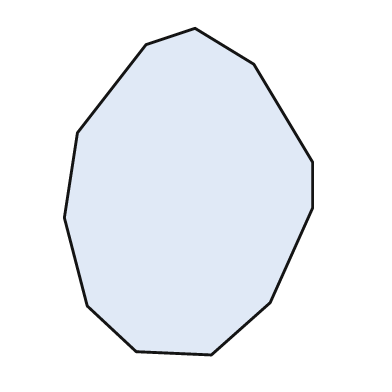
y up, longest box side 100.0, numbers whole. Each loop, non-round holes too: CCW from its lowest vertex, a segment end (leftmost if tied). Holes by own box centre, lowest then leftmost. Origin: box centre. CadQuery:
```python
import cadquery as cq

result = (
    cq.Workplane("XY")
    .moveTo(7.0, -50.0)
    .lineTo(25.0, -34.0)
    .lineTo(38.0, -5.0)
    .lineTo(38.0, 9.0)
    .lineTo(20.0, 39.0)
    .lineTo(2.0, 50.0)
    .lineTo(-13.0, 45.0)
    .lineTo(-34.0, 18.0)
    .lineTo(-38.0, -8.0)
    .lineTo(-31.0, -35.0)
    .lineTo(-16.0, -49.0)
    .close()
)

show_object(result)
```